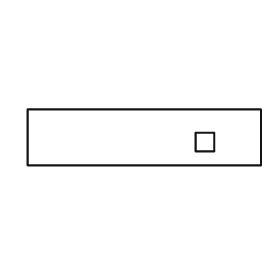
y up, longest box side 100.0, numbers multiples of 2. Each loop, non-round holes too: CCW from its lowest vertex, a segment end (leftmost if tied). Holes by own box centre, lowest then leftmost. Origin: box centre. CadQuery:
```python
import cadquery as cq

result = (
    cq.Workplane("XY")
    .moveTo(-50.0, -12.0)
    .lineTo(50.0, -12.0)
    .lineTo(50.0, 12.0)
    .lineTo(-50.0, 12.0)
    .close()
    .moveTo(22.0, -6.0)
    .lineTo(30.0, -6.0)
    .lineTo(30.0, 2.0)
    .lineTo(22.0, 2.0)
    .close()
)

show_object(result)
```